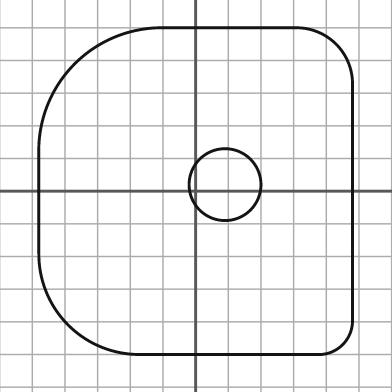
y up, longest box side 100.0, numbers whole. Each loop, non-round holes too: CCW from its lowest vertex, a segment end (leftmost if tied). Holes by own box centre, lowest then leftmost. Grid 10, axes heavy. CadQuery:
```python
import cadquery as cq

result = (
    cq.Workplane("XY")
    .moveTo(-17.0, -50.0)
    .lineTo(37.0, -50.0)
    .threePointArc((45.0, -47.0), (48.0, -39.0))
    .lineTo(48.0, 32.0)
    .threePointArc((43.0, 45.0), (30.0, 50.0))
    .lineTo(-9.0, 50.0)
    .threePointArc((-37.0, 39.0), (-48.0, 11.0))
    .lineTo(-48.0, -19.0)
    .threePointArc((-39.0, -41.0), (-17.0, -50.0))
    .close()
    .moveTo(9.0, 2.0)
    .circle(11.0)
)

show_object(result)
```